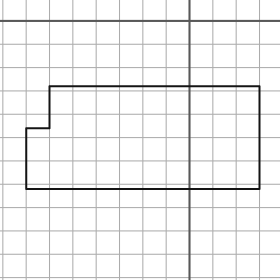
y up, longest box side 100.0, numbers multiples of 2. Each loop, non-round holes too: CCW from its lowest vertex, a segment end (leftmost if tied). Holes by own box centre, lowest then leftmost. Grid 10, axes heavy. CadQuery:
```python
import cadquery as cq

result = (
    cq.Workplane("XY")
    .moveTo(-70.0, -72.0)
    .lineTo(30.0, -72.0)
    .lineTo(30.0, -28.0)
    .lineTo(-60.0, -28.0)
    .lineTo(-60.0, -46.0)
    .lineTo(-70.0, -46.0)
    .close()
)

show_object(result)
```